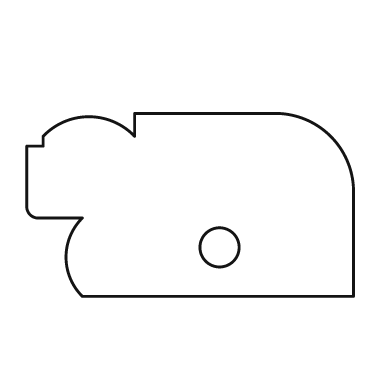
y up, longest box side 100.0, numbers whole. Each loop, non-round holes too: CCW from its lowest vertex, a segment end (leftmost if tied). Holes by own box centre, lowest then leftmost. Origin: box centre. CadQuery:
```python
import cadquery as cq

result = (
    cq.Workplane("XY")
    .moveTo(-33.0, -28.0)
    .lineTo(50.0, -28.0)
    .lineTo(50.0, 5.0)
    .threePointArc((43.0, 21.0), (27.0, 28.0))
    .lineTo(-17.0, 28.0)
    .lineTo(-17.0, 21.0)
    .threePointArc((-31.0, 27.0), (-45.0, 21.0))
    .lineTo(-45.0, 18.0)
    .lineTo(-50.0, 18.0)
    .lineTo(-50.0, 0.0)
    .threePointArc((-49.0, -3.0), (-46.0, -4.0))
    .lineTo(-33.0, -4.0)
    .threePointArc((-38.0, -16.0), (-33.0, -28.0))
    .close()
    .moveTo(9.0, -13.0)
    .circle(6.0)
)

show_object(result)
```